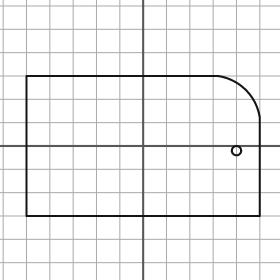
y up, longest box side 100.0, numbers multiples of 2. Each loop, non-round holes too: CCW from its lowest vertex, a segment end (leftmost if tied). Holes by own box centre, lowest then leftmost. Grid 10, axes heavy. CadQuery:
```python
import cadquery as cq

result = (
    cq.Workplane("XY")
    .moveTo(-50.0, -30.0)
    .lineTo(50.0, -30.0)
    .lineTo(50.0, 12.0)
    .threePointArc((44.0, 24.0), (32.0, 30.0))
    .lineTo(-50.0, 30.0)
    .close()
    .moveTo(40.0, -2.0)
    .circle(2.0)
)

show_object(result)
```